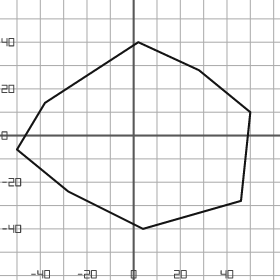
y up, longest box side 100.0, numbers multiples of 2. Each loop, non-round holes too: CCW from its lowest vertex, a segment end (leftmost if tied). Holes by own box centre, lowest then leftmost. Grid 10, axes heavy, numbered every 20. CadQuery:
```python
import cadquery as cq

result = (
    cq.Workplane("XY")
    .moveTo(4.0, -40.0)
    .lineTo(46.0, -28.0)
    .lineTo(50.0, 10.0)
    .lineTo(28.0, 28.0)
    .lineTo(2.0, 40.0)
    .lineTo(-38.0, 14.0)
    .lineTo(-50.0, -6.0)
    .lineTo(-28.0, -24.0)
    .close()
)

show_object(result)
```